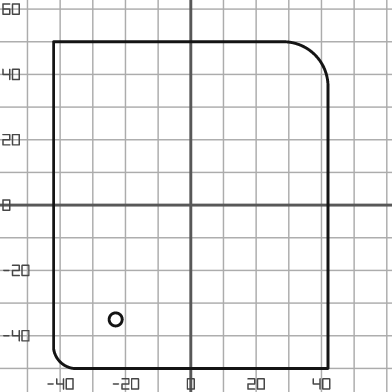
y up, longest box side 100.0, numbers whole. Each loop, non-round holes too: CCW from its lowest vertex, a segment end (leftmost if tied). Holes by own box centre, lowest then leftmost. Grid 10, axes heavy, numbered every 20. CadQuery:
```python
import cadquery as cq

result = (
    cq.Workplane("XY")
    .moveTo(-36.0, -50.0)
    .lineTo(42.0, -50.0)
    .lineTo(42.0, 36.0)
    .threePointArc((38.0, 46.0), (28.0, 50.0))
    .lineTo(-42.0, 50.0)
    .lineTo(-42.0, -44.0)
    .threePointArc((-40.0, -48.0), (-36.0, -50.0))
    .close()
    .moveTo(-23.0, -35.0)
    .circle(2.0)
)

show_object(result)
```